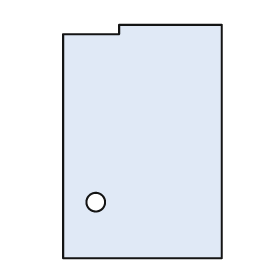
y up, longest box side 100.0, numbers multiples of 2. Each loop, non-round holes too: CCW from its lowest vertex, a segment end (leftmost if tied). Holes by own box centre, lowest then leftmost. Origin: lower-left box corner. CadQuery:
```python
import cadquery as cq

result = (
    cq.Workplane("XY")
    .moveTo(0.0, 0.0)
    .lineTo(68.0, 0.0)
    .lineTo(68.0, 100.0)
    .lineTo(24.0, 100.0)
    .lineTo(24.0, 96.0)
    .lineTo(0.0, 96.0)
    .close()
    .moveTo(14.0, 24.0)
    .circle(4.0)
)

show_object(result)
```